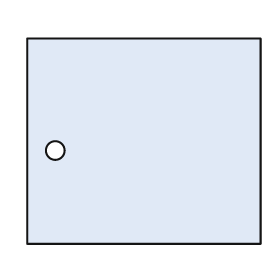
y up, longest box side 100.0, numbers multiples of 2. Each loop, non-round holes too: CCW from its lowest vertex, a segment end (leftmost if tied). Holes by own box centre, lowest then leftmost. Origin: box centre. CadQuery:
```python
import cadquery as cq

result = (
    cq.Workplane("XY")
    .moveTo(-50.0, -44.0)
    .lineTo(50.0, -44.0)
    .lineTo(50.0, 44.0)
    .lineTo(-50.0, 44.0)
    .close()
    .moveTo(-38.0, -4.0)
    .circle(4.0)
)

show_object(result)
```